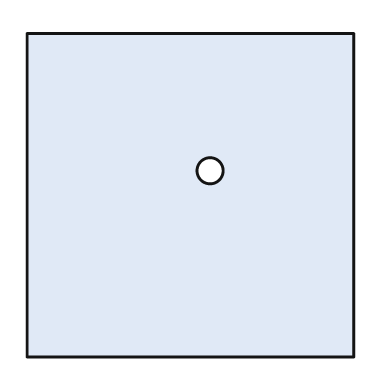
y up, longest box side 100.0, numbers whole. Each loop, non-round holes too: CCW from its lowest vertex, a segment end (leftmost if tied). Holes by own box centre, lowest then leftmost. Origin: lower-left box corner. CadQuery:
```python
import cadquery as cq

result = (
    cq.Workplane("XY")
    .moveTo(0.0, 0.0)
    .lineTo(100.0, 0.0)
    .lineTo(100.0, 99.0)
    .lineTo(0.0, 99.0)
    .close()
    .moveTo(56.0, 57.0)
    .circle(4.0)
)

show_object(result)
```